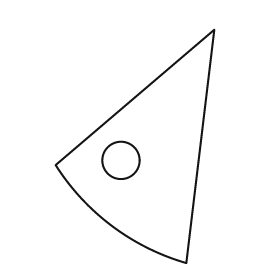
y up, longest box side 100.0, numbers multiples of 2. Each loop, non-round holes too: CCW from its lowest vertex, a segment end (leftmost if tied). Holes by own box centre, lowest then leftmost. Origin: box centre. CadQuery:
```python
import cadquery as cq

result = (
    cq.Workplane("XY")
    .moveTo(22.0, -50.0)
    .lineTo(34.0, 50.0)
    .lineTo(-34.0, -8.0)
    .threePointArc((-10.0, -34.0), (22.0, -50.0))
    .close()
    .moveTo(-6.0, -6.0)
    .circle(8.0)
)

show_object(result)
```